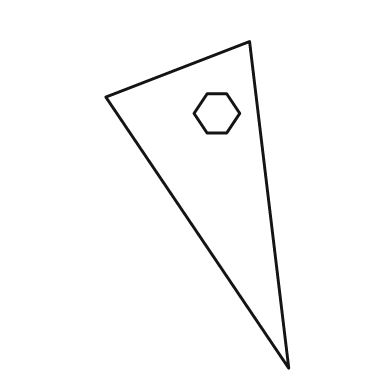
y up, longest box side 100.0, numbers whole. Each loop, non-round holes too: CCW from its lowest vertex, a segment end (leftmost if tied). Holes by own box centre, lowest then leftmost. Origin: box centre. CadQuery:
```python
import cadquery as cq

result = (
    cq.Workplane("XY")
    .moveTo(28.0, -50.0)
    .lineTo(16.0, 50.0)
    .lineTo(-28.0, 33.0)
    .close()
    .moveTo(3.0, 22.0)
    .lineTo(9.0, 22.0)
    .lineTo(13.0, 28.0)
    .lineTo(9.0, 34.0)
    .lineTo(3.0, 34.0)
    .lineTo(-1.0, 28.0)
    .close()
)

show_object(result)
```